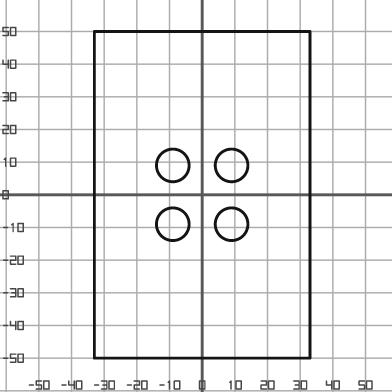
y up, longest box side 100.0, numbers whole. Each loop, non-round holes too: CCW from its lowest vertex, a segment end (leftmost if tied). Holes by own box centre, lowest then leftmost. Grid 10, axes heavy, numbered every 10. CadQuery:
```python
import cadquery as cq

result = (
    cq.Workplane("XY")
    .moveTo(-33.0, -50.0)
    .lineTo(33.0, -50.0)
    .lineTo(33.0, 50.0)
    .lineTo(-33.0, 50.0)
    .close()
    .moveTo(-9.0, -9.0)
    .circle(5.0)
    .moveTo(9.0, -9.0)
    .circle(5.0)
    .moveTo(-9.0, 9.0)
    .circle(5.0)
    .moveTo(9.0, 9.0)
    .circle(5.0)
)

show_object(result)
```